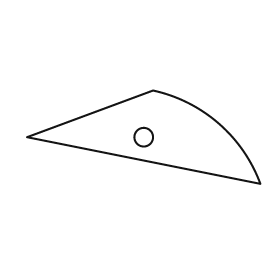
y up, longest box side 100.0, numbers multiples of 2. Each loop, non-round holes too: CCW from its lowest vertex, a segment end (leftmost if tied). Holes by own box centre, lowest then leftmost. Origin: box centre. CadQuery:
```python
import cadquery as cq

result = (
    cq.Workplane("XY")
    .moveTo(50.0, -20.0)
    .threePointArc((32.0, 6.0), (4.0, 20.0))
    .lineTo(-50.0, 0.0)
    .close()
    .moveTo(0.0, 0.0)
    .circle(4.0)
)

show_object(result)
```